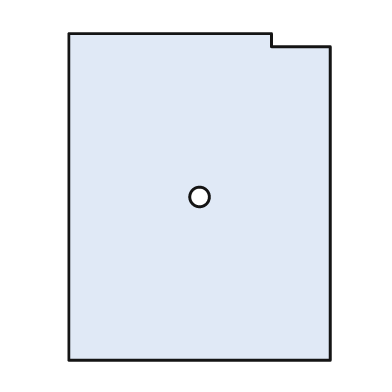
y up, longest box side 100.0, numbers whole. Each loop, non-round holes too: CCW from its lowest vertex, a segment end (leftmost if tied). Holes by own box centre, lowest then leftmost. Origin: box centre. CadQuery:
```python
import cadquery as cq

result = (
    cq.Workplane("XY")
    .moveTo(-40.0, -50.0)
    .lineTo(40.0, -50.0)
    .lineTo(40.0, 46.0)
    .lineTo(22.0, 46.0)
    .lineTo(22.0, 50.0)
    .lineTo(-40.0, 50.0)
    .close()
    .moveTo(0.0, 0.0)
    .circle(3.0)
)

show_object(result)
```